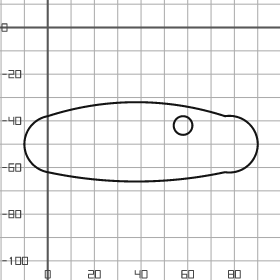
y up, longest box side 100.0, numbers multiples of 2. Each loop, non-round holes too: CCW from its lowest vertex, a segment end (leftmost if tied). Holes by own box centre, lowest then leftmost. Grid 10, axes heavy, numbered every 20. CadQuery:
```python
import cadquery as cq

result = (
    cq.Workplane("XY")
    .moveTo(0.0, -62.0)
    .threePointArc((38.0, -66.0), (76.0, -62.0))
    .threePointArc((90.0, -50.0), (76.0, -38.0))
    .threePointArc((38.0, -32.0), (0.0, -38.0))
    .threePointArc((-10.0, -50.0), (0.0, -62.0))
    .close()
    .moveTo(58.0, -42.0)
    .circle(4.0)
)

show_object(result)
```